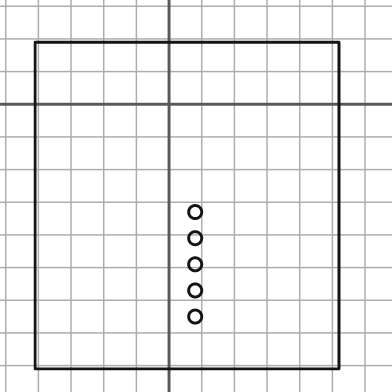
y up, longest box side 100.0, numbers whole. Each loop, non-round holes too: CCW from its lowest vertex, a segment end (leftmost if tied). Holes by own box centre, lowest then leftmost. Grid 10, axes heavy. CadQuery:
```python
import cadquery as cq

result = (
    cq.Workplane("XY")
    .moveTo(-41.0, -81.0)
    .lineTo(52.0, -81.0)
    .lineTo(52.0, 19.0)
    .lineTo(-41.0, 19.0)
    .close()
    .moveTo(8.0, -65.0)
    .circle(2.0)
    .moveTo(8.0, -57.0)
    .circle(2.0)
    .moveTo(8.0, -49.0)
    .circle(2.0)
    .moveTo(8.0, -41.0)
    .circle(2.0)
    .moveTo(8.0, -33.0)
    .circle(2.0)
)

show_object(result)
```